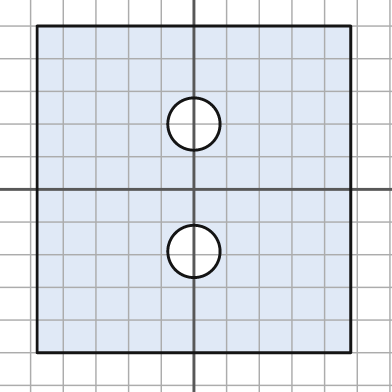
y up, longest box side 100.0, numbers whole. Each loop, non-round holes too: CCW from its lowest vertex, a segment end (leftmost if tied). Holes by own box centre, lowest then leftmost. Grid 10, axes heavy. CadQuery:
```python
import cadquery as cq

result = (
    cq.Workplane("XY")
    .moveTo(-48.0, -50.0)
    .lineTo(48.0, -50.0)
    .lineTo(48.0, 50.0)
    .lineTo(-48.0, 50.0)
    .close()
    .moveTo(0.0, -19.0)
    .circle(8.0)
    .moveTo(0.0, 20.0)
    .circle(8.0)
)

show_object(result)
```